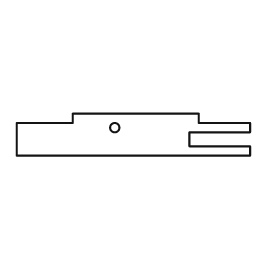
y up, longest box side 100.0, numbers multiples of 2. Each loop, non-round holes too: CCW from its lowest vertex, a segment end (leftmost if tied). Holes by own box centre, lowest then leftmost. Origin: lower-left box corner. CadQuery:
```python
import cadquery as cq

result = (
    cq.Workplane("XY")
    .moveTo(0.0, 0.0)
    .lineTo(100.0, 0.0)
    .lineTo(100.0, 4.0)
    .lineTo(74.0, 4.0)
    .lineTo(74.0, 10.0)
    .lineTo(100.0, 10.0)
    .lineTo(100.0, 14.0)
    .lineTo(78.0, 14.0)
    .lineTo(78.0, 18.0)
    .lineTo(24.0, 18.0)
    .lineTo(24.0, 14.0)
    .lineTo(0.0, 14.0)
    .close()
    .moveTo(42.0, 12.0)
    .circle(2.0)
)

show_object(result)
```